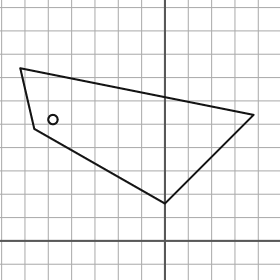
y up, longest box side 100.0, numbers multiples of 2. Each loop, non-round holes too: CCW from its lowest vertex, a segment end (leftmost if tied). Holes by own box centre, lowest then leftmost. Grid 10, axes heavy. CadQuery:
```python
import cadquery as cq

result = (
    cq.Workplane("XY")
    .moveTo(0.0, 16.0)
    .lineTo(38.0, 54.0)
    .lineTo(-62.0, 74.0)
    .lineTo(-56.0, 48.0)
    .close()
    .moveTo(-48.0, 52.0)
    .circle(2.0)
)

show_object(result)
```